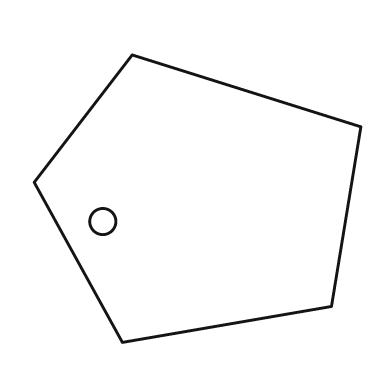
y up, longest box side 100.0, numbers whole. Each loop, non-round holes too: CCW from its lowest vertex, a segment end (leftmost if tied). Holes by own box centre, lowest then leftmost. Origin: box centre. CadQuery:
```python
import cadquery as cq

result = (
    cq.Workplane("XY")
    .moveTo(-23.0, -44.0)
    .lineTo(41.0, -33.0)
    .lineTo(50.0, 22.0)
    .lineTo(-20.0, 44.0)
    .lineTo(-50.0, 5.0)
    .close()
    .moveTo(-29.0, -7.0)
    .circle(4.0)
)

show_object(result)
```